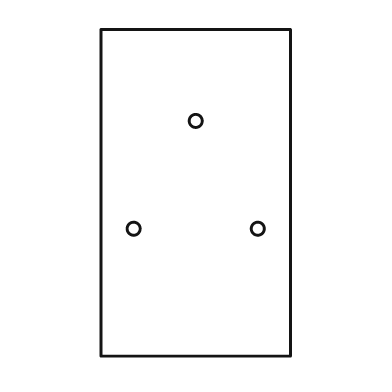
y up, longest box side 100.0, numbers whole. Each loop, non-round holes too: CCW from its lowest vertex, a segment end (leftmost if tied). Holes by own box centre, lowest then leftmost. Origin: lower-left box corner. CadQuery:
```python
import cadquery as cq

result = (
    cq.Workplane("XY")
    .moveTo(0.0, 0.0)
    .lineTo(58.0, 0.0)
    .lineTo(58.0, 100.0)
    .lineTo(0.0, 100.0)
    .close()
    .moveTo(10.0, 39.0)
    .circle(2.0)
    .moveTo(48.0, 39.0)
    .circle(2.0)
    .moveTo(29.0, 72.0)
    .circle(2.0)
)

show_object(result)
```